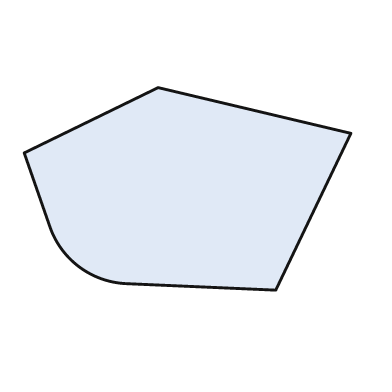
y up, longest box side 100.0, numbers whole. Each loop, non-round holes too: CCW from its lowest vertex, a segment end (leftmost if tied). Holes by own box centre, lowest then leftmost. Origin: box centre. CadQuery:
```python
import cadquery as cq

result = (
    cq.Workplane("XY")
    .moveTo(27.0, -31.0)
    .lineTo(50.0, 17.0)
    .lineTo(-9.0, 31.0)
    .lineTo(-50.0, 11.0)
    .lineTo(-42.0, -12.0)
    .threePointArc((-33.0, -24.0), (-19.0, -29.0))
    .close()
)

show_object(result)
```